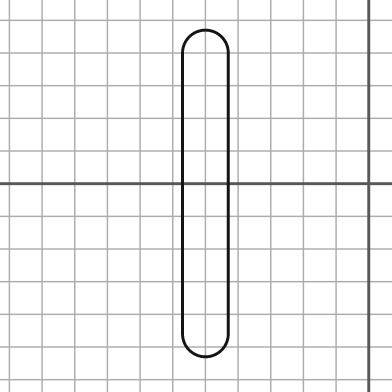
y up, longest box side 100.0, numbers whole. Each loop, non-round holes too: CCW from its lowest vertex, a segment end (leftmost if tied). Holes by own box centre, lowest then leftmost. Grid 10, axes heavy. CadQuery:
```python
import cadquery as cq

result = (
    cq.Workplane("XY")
    .moveTo(-57.0, -46.0)
    .threePointArc((-50.0, -53.0), (-43.0, -46.0))
    .lineTo(-43.0, 40.0)
    .threePointArc((-50.0, 47.0), (-57.0, 40.0))
    .close()
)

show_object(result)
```